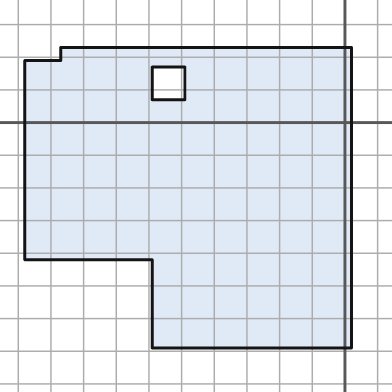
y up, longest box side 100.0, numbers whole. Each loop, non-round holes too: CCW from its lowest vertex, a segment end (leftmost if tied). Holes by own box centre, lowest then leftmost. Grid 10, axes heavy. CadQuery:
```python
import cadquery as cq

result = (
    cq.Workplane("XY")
    .moveTo(-59.0, -69.0)
    .lineTo(2.0, -69.0)
    .lineTo(2.0, 23.0)
    .lineTo(-87.0, 23.0)
    .lineTo(-87.0, 19.0)
    .lineTo(-98.0, 19.0)
    .lineTo(-98.0, -42.0)
    .lineTo(-59.0, -42.0)
    .close()
    .moveTo(-59.0, 7.0)
    .lineTo(-49.0, 7.0)
    .lineTo(-49.0, 17.0)
    .lineTo(-59.0, 17.0)
    .close()
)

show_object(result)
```